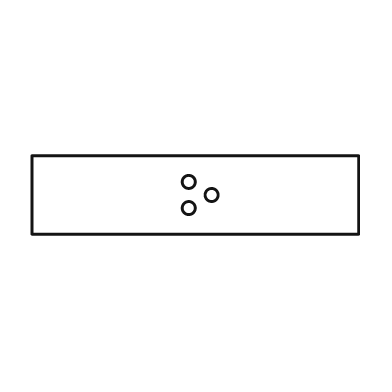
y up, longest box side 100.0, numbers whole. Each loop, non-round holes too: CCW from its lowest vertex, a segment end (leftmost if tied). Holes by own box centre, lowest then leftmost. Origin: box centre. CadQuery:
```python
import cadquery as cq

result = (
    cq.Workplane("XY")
    .moveTo(-50.0, -12.0)
    .lineTo(50.0, -12.0)
    .lineTo(50.0, 12.0)
    .lineTo(-50.0, 12.0)
    .close()
    .moveTo(-2.0, -4.0)
    .circle(2.0)
    .moveTo(5.0, 0.0)
    .circle(2.0)
    .moveTo(-2.0, 4.0)
    .circle(2.0)
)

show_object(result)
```